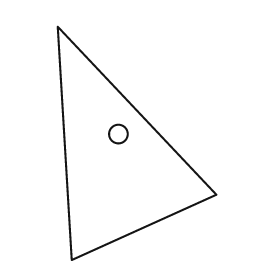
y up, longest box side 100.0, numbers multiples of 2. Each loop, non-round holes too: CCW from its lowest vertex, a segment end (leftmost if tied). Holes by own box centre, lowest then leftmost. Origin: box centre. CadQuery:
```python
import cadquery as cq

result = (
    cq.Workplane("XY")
    .moveTo(-28.0, -50.0)
    .lineTo(34.0, -22.0)
    .lineTo(-34.0, 50.0)
    .close()
    .moveTo(-8.0, 4.0)
    .circle(4.0)
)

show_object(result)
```